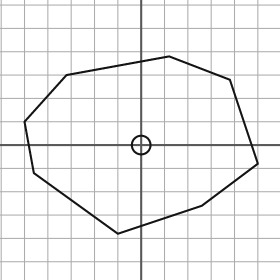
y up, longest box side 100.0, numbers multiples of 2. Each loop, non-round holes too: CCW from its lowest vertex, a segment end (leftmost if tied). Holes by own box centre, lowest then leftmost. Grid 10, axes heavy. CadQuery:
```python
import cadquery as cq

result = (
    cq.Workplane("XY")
    .moveTo(-10.0, -38.0)
    .lineTo(26.0, -26.0)
    .lineTo(50.0, -8.0)
    .lineTo(38.0, 28.0)
    .lineTo(12.0, 38.0)
    .lineTo(-32.0, 30.0)
    .lineTo(-50.0, 10.0)
    .lineTo(-46.0, -12.0)
    .close()
    .moveTo(0.0, 0.0)
    .circle(4.0)
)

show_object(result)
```